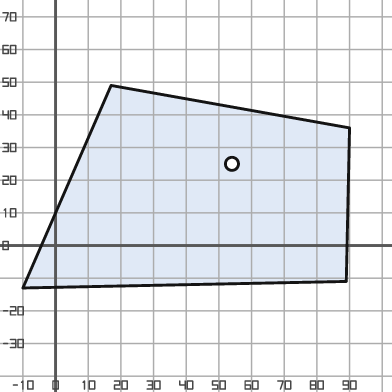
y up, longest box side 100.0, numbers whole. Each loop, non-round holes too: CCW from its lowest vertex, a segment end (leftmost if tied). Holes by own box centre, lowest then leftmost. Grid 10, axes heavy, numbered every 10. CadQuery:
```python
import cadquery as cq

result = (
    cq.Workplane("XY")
    .moveTo(-10.0, -13.0)
    .lineTo(89.0, -11.0)
    .lineTo(90.0, 36.0)
    .lineTo(17.0, 49.0)
    .close()
    .moveTo(54.0, 25.0)
    .circle(2.0)
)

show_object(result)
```